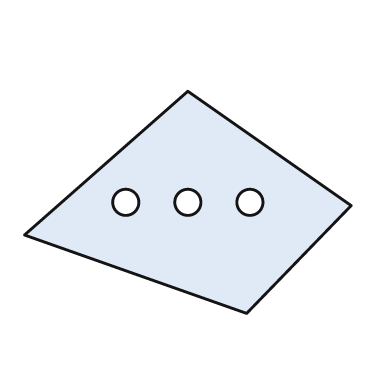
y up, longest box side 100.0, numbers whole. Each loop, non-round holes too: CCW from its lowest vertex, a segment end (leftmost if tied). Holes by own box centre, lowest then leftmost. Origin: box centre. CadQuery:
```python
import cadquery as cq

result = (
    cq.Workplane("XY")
    .moveTo(18.0, -34.0)
    .lineTo(50.0, -1.0)
    .lineTo(0.0, 34.0)
    .lineTo(-50.0, -10.0)
    .close()
    .moveTo(-19.0, 0.0)
    .circle(4.0)
    .moveTo(0.0, 0.0)
    .circle(4.0)
    .moveTo(19.0, 0.0)
    .circle(4.0)
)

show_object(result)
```